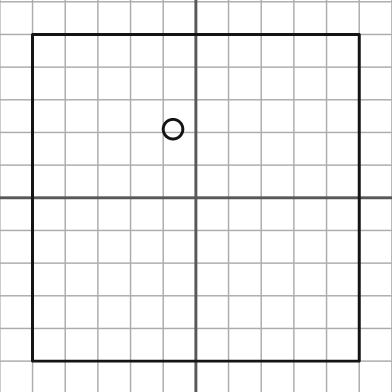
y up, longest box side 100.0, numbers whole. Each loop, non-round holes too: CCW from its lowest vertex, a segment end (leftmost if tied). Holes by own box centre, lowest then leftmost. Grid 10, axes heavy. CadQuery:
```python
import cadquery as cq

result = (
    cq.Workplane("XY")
    .moveTo(-50.0, -50.0)
    .lineTo(50.0, -50.0)
    .lineTo(50.0, 50.0)
    .lineTo(-50.0, 50.0)
    .close()
    .moveTo(-7.0, 21.0)
    .circle(3.0)
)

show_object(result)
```